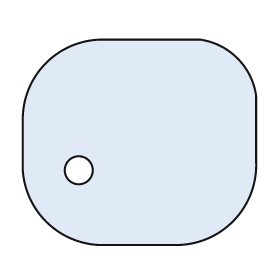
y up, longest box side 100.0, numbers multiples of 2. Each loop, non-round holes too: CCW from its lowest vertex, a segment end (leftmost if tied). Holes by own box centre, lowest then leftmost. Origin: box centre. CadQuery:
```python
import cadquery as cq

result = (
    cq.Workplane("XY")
    .moveTo(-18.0, -44.0)
    .lineTo(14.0, -44.0)
    .threePointArc((40.0, -34.0), (50.0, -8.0))
    .lineTo(50.0, 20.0)
    .threePointArc((42.0, 36.0), (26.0, 44.0))
    .lineTo(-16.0, 44.0)
    .threePointArc((-40.0, 34.0), (-50.0, 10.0))
    .lineTo(-50.0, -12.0)
    .threePointArc((-40.0, -34.0), (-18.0, -44.0))
    .close()
    .moveTo(-26.0, -12.0)
    .circle(6.0)
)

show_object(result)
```